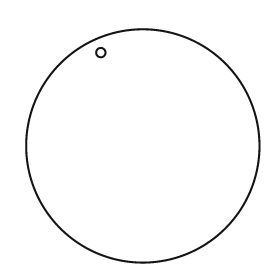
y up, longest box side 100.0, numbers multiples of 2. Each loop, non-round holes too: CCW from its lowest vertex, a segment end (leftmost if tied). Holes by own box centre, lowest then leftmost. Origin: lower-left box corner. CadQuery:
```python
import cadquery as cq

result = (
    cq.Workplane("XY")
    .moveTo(50.0, 50.0)
    .circle(50.0)
    .moveTo(32.0, 90.0)
    .circle(2.0)
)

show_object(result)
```